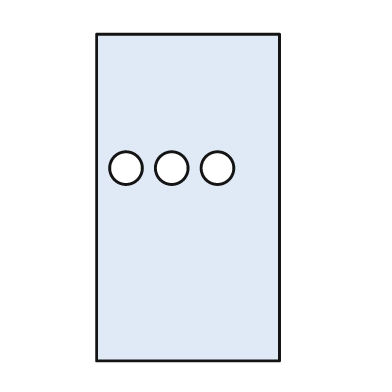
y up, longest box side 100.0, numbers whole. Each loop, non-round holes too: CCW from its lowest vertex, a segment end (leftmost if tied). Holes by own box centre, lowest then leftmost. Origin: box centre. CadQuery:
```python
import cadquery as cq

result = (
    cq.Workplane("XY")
    .moveTo(-28.0, -50.0)
    .lineTo(28.0, -50.0)
    .lineTo(28.0, 50.0)
    .lineTo(-28.0, 50.0)
    .close()
    .moveTo(-19.0, 9.0)
    .circle(5.0)
    .moveTo(-5.0, 9.0)
    .circle(5.0)
    .moveTo(9.0, 9.0)
    .circle(5.0)
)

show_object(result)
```